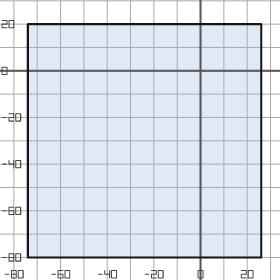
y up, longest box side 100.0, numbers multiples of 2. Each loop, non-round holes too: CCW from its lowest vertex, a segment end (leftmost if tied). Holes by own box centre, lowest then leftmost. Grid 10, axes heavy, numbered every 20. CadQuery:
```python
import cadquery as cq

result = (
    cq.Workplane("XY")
    .moveTo(-74.0, -80.0)
    .lineTo(26.0, -80.0)
    .lineTo(26.0, 20.0)
    .lineTo(-74.0, 20.0)
    .close()
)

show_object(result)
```